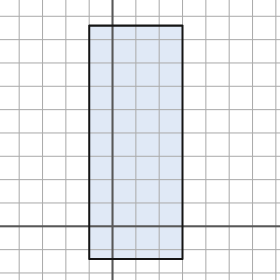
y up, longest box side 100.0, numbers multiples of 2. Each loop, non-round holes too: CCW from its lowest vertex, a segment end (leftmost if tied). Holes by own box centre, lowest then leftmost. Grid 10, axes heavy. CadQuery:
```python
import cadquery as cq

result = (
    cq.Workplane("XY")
    .moveTo(-10.0, -14.0)
    .lineTo(30.0, -14.0)
    .lineTo(30.0, 86.0)
    .lineTo(-10.0, 86.0)
    .close()
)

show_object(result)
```